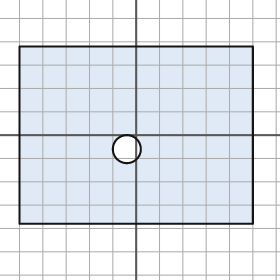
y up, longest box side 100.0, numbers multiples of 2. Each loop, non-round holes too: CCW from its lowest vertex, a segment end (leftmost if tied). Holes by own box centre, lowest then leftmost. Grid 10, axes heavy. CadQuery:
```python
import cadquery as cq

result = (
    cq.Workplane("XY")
    .moveTo(-50.0, -38.0)
    .lineTo(50.0, -38.0)
    .lineTo(50.0, 38.0)
    .lineTo(-50.0, 38.0)
    .close()
    .moveTo(-4.0, -6.0)
    .circle(6.0)
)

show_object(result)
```